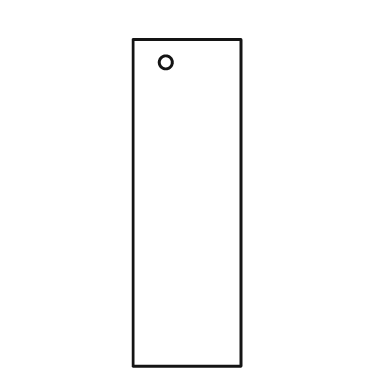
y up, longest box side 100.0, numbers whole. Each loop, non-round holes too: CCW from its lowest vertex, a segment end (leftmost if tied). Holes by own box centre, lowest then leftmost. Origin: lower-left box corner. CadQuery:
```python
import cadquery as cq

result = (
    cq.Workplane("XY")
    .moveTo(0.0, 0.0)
    .lineTo(33.0, 0.0)
    .lineTo(33.0, 100.0)
    .lineTo(0.0, 100.0)
    .close()
    .moveTo(10.0, 93.0)
    .circle(2.0)
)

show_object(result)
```